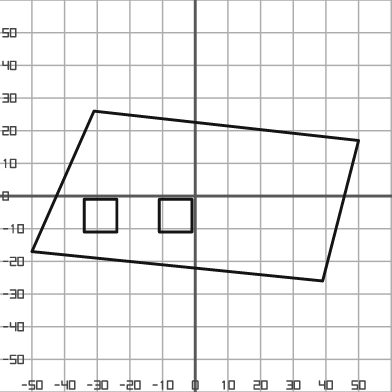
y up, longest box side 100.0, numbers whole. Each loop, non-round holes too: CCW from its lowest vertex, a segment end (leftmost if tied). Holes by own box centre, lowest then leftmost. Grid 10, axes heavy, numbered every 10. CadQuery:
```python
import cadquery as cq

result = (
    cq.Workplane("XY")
    .moveTo(39.0, -26.0)
    .lineTo(50.0, 17.0)
    .lineTo(-31.0, 26.0)
    .lineTo(-50.0, -17.0)
    .close()
    .moveTo(-34.0, -11.0)
    .lineTo(-24.0, -11.0)
    .lineTo(-24.0, -1.0)
    .lineTo(-34.0, -1.0)
    .close()
    .moveTo(-11.0, -11.0)
    .lineTo(-1.0, -11.0)
    .lineTo(-1.0, -1.0)
    .lineTo(-11.0, -1.0)
    .close()
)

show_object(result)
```